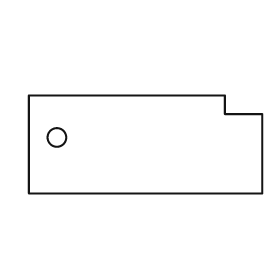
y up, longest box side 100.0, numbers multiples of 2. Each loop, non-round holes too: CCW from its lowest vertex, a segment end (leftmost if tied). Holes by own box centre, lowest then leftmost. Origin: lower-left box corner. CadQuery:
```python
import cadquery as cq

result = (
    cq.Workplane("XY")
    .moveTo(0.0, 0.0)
    .lineTo(100.0, 0.0)
    .lineTo(100.0, 34.0)
    .lineTo(84.0, 34.0)
    .lineTo(84.0, 42.0)
    .lineTo(0.0, 42.0)
    .close()
    .moveTo(12.0, 24.0)
    .circle(4.0)
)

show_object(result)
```